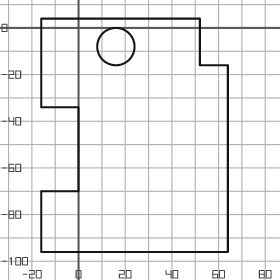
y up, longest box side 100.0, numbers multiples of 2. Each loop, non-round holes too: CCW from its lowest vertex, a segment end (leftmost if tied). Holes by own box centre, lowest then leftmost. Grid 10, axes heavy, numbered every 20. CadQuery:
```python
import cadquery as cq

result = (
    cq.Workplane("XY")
    .moveTo(-16.0, -96.0)
    .lineTo(64.0, -96.0)
    .lineTo(64.0, -16.0)
    .lineTo(52.0, -16.0)
    .lineTo(52.0, 4.0)
    .lineTo(-16.0, 4.0)
    .lineTo(-16.0, -34.0)
    .lineTo(0.0, -34.0)
    .lineTo(0.0, -70.0)
    .lineTo(-16.0, -70.0)
    .close()
    .moveTo(16.0, -8.0)
    .circle(8.0)
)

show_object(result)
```